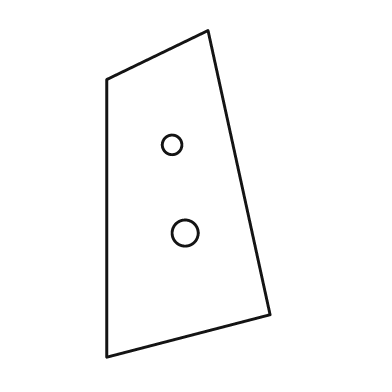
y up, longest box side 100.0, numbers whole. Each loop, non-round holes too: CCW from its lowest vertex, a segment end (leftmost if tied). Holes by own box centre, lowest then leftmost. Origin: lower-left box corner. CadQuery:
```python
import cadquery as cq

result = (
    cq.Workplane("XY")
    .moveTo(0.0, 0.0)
    .lineTo(50.0, 13.0)
    .lineTo(31.0, 100.0)
    .lineTo(0.0, 85.0)
    .close()
    .moveTo(24.0, 38.0)
    .circle(4.0)
    .moveTo(20.0, 65.0)
    .circle(3.0)
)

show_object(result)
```